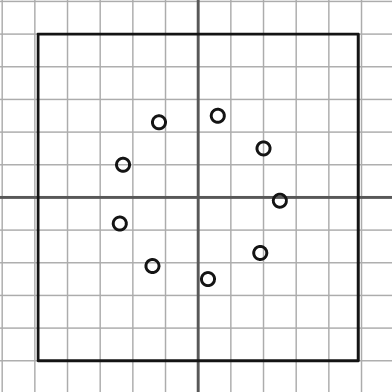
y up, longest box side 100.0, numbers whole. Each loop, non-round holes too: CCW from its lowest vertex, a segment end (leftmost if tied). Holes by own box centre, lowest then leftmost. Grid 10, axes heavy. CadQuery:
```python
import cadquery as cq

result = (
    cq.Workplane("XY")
    .moveTo(-49.0, -50.0)
    .lineTo(49.0, -50.0)
    .lineTo(49.0, 50.0)
    .lineTo(-49.0, 50.0)
    .close()
    .moveTo(3.0, -25.0)
    .circle(2.0)
    .moveTo(-14.0, -21.0)
    .circle(2.0)
    .moveTo(19.0, -17.0)
    .circle(2.0)
    .moveTo(-24.0, -8.0)
    .circle(2.0)
    .moveTo(25.0, -1.0)
    .circle(2.0)
    .moveTo(-23.0, 10.0)
    .circle(2.0)
    .moveTo(20.0, 15.0)
    .circle(2.0)
    .moveTo(-12.0, 23.0)
    .circle(2.0)
    .moveTo(6.0, 25.0)
    .circle(2.0)
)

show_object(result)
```